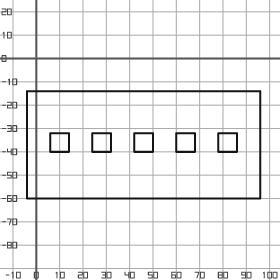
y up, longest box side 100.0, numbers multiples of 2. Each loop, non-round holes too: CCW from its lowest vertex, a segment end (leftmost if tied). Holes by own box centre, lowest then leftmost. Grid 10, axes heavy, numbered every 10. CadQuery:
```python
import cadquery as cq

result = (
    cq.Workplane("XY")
    .moveTo(-4.0, -60.0)
    .lineTo(96.0, -60.0)
    .lineTo(96.0, -14.0)
    .lineTo(-4.0, -14.0)
    .close()
    .moveTo(6.0, -40.0)
    .lineTo(14.0, -40.0)
    .lineTo(14.0, -32.0)
    .lineTo(6.0, -32.0)
    .close()
    .moveTo(24.0, -40.0)
    .lineTo(32.0, -40.0)
    .lineTo(32.0, -32.0)
    .lineTo(24.0, -32.0)
    .close()
    .moveTo(42.0, -40.0)
    .lineTo(50.0, -40.0)
    .lineTo(50.0, -32.0)
    .lineTo(42.0, -32.0)
    .close()
    .moveTo(60.0, -40.0)
    .lineTo(68.0, -40.0)
    .lineTo(68.0, -32.0)
    .lineTo(60.0, -32.0)
    .close()
    .moveTo(78.0, -40.0)
    .lineTo(86.0, -40.0)
    .lineTo(86.0, -32.0)
    .lineTo(78.0, -32.0)
    .close()
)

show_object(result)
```